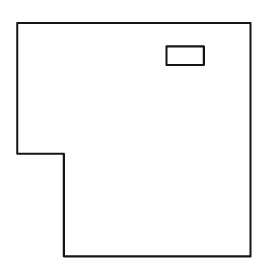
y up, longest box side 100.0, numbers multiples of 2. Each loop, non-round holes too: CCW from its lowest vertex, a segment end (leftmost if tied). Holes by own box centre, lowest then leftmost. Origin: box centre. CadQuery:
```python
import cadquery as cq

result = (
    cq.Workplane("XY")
    .moveTo(-30.0, -50.0)
    .lineTo(50.0, -50.0)
    .lineTo(50.0, 50.0)
    .lineTo(-50.0, 50.0)
    .lineTo(-50.0, -6.0)
    .lineTo(-30.0, -6.0)
    .close()
    .moveTo(14.0, 32.0)
    .lineTo(30.0, 32.0)
    .lineTo(30.0, 40.0)
    .lineTo(14.0, 40.0)
    .close()
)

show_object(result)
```